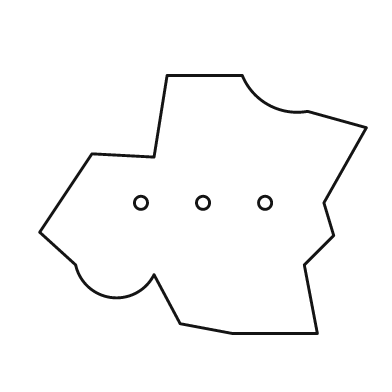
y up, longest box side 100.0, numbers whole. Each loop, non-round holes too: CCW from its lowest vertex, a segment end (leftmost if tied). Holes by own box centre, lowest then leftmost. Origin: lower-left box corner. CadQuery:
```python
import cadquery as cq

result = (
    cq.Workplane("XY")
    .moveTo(59.0, 0.0)
    .lineTo(85.0, 0.0)
    .lineTo(81.0, 21.0)
    .lineTo(90.0, 30.0)
    .lineTo(87.0, 40.0)
    .lineTo(100.0, 63.0)
    .lineTo(82.0, 68.0)
    .threePointArc((70.0, 70.0), (62.0, 79.0))
    .lineTo(39.0, 79.0)
    .lineTo(35.0, 54.0)
    .lineTo(16.0, 55.0)
    .lineTo(0.0, 31.0)
    .lineTo(11.0, 21.0)
    .threePointArc((22.0, 11.0), (35.0, 18.0))
    .lineTo(43.0, 3.0)
    .close()
    .moveTo(31.0, 40.0)
    .circle(2.0)
    .moveTo(50.0, 40.0)
    .circle(2.0)
    .moveTo(69.0, 40.0)
    .circle(2.0)
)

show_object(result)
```